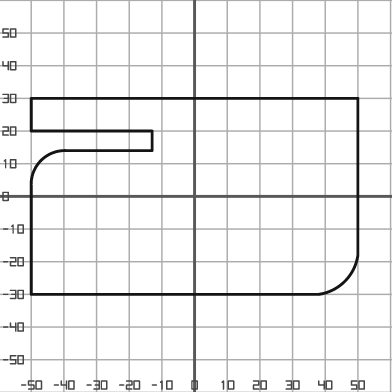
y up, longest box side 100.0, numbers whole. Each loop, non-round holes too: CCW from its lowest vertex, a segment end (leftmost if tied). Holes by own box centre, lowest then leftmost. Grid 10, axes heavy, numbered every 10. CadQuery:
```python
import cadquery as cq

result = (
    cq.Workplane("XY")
    .moveTo(-50.0, -30.0)
    .lineTo(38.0, -30.0)
    .threePointArc((46.0, -26.0), (50.0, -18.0))
    .lineTo(50.0, 30.0)
    .lineTo(-50.0, 30.0)
    .lineTo(-50.0, 20.0)
    .lineTo(-13.0, 20.0)
    .lineTo(-13.0, 14.0)
    .lineTo(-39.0, 14.0)
    .threePointArc((-47.0, 11.0), (-50.0, 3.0))
    .close()
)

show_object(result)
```